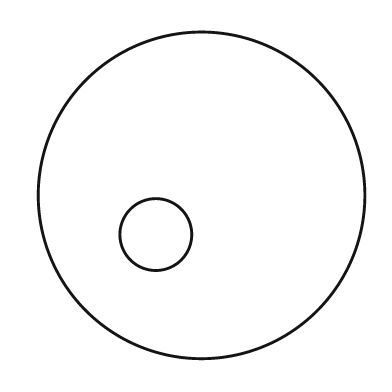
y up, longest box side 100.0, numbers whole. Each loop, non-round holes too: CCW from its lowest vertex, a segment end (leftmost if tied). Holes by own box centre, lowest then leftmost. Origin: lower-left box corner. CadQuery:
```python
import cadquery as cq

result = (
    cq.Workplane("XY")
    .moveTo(50.0, 50.0)
    .circle(50.0)
    .moveTo(36.0, 38.0)
    .circle(11.0)
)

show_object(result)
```